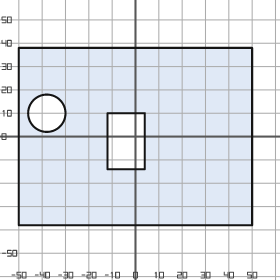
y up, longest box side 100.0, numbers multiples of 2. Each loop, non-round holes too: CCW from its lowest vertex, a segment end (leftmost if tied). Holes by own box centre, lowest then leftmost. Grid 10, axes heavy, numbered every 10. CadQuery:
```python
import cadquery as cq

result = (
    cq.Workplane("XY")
    .moveTo(-50.0, -38.0)
    .lineTo(50.0, -38.0)
    .lineTo(50.0, 38.0)
    .lineTo(-50.0, 38.0)
    .close()
    .moveTo(-12.0, -14.0)
    .lineTo(4.0, -14.0)
    .lineTo(4.0, 10.0)
    .lineTo(-12.0, 10.0)
    .close()
    .moveTo(-38.0, 10.0)
    .circle(8.0)
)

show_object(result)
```